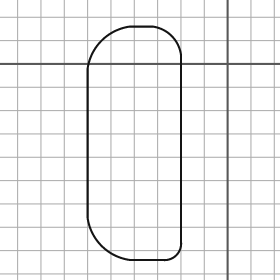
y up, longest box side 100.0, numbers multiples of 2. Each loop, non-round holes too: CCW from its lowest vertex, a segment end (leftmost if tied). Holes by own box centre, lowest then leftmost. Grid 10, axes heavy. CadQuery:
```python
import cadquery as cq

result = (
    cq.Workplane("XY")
    .moveTo(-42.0, -84.0)
    .lineTo(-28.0, -84.0)
    .threePointArc((-22.0, -82.0), (-20.0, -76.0))
    .lineTo(-20.0, 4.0)
    .threePointArc((-24.0, 12.0), (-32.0, 16.0))
    .lineTo(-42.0, 16.0)
    .threePointArc((-54.0, 10.0), (-60.0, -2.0))
    .lineTo(-60.0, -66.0)
    .threePointArc((-54.0, -78.0), (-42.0, -84.0))
    .close()
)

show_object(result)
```